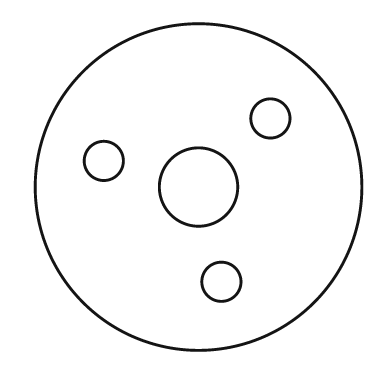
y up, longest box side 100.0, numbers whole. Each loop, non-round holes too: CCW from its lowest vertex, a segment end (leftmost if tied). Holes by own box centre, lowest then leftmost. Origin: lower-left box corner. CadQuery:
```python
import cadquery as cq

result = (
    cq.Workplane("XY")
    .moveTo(50.0, 50.0)
    .circle(50.0)
    .moveTo(57.0, 21.0)
    .circle(6.0)
    .moveTo(50.0, 50.0)
    .circle(12.0)
    .moveTo(21.0, 58.0)
    .circle(6.0)
    .moveTo(72.0, 71.0)
    .circle(6.0)
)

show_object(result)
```